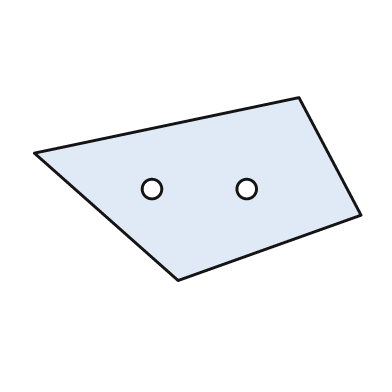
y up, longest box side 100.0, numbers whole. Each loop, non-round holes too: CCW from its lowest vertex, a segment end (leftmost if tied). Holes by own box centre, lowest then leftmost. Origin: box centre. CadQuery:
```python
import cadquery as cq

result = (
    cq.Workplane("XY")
    .moveTo(-6.0, -28.0)
    .lineTo(50.0, -8.0)
    .lineTo(31.0, 28.0)
    .lineTo(-50.0, 11.0)
    .close()
    .moveTo(-14.0, 0.0)
    .circle(3.0)
    .moveTo(15.0, 0.0)
    .circle(3.0)
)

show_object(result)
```